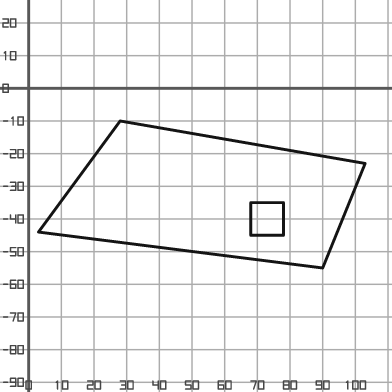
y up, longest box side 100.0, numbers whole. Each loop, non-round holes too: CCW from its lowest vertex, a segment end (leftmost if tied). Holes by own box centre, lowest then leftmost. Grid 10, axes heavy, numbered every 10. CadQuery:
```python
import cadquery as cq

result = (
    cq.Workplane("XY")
    .moveTo(90.0, -55.0)
    .lineTo(103.0, -23.0)
    .lineTo(28.0, -10.0)
    .lineTo(3.0, -44.0)
    .close()
    .moveTo(68.0, -45.0)
    .lineTo(78.0, -45.0)
    .lineTo(78.0, -35.0)
    .lineTo(68.0, -35.0)
    .close()
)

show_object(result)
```